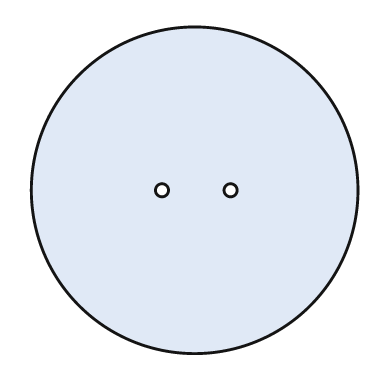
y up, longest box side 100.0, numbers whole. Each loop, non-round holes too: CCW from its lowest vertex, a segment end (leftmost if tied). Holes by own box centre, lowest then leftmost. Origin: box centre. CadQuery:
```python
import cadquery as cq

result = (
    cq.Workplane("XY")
    .moveTo(0.0, 0.0)
    .circle(50.0)
    .moveTo(-10.0, 0.0)
    .circle(2.0)
    .moveTo(11.0, 0.0)
    .circle(2.0)
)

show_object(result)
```